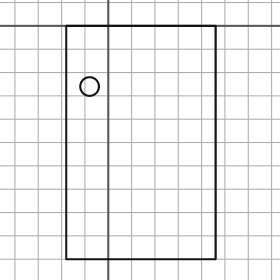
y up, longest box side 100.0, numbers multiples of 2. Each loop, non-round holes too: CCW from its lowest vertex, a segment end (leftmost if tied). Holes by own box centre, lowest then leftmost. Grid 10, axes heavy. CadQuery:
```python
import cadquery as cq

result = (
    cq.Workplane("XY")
    .moveTo(-18.0, -100.0)
    .lineTo(46.0, -100.0)
    .lineTo(46.0, 0.0)
    .lineTo(-18.0, 0.0)
    .close()
    .moveTo(-8.0, -26.0)
    .circle(4.0)
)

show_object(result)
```